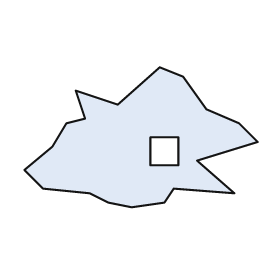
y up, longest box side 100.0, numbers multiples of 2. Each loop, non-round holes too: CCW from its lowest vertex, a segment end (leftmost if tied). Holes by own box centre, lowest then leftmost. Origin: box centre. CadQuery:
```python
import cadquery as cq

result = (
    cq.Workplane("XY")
    .moveTo(-4.0, -30.0)
    .lineTo(10.0, -28.0)
    .lineTo(14.0, -22.0)
    .lineTo(40.0, -24.0)
    .lineTo(24.0, -10.0)
    .lineTo(50.0, -2.0)
    .lineTo(42.0, 6.0)
    .lineTo(28.0, 12.0)
    .lineTo(18.0, 26.0)
    .lineTo(8.0, 30.0)
    .lineTo(-10.0, 14.0)
    .lineTo(-28.0, 20.0)
    .lineTo(-24.0, 8.0)
    .lineTo(-32.0, 6.0)
    .lineTo(-38.0, -4.0)
    .lineTo(-50.0, -14.0)
    .lineTo(-42.0, -22.0)
    .lineTo(-22.0, -24.0)
    .lineTo(-14.0, -28.0)
    .close()
    .moveTo(4.0, -12.0)
    .lineTo(16.0, -12.0)
    .lineTo(16.0, 0.0)
    .lineTo(4.0, 0.0)
    .close()
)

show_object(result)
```